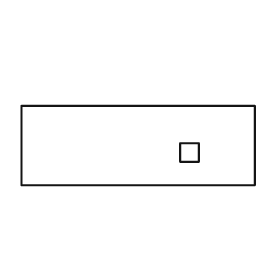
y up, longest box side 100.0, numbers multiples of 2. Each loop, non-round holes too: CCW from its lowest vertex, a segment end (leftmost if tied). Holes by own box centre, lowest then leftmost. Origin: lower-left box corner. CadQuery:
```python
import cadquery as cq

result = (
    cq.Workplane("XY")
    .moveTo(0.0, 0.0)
    .lineTo(100.0, 0.0)
    .lineTo(100.0, 34.0)
    .lineTo(0.0, 34.0)
    .close()
    .moveTo(68.0, 10.0)
    .lineTo(76.0, 10.0)
    .lineTo(76.0, 18.0)
    .lineTo(68.0, 18.0)
    .close()
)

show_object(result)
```